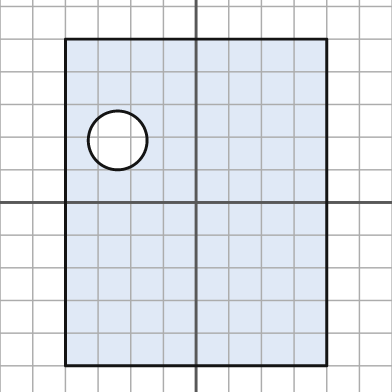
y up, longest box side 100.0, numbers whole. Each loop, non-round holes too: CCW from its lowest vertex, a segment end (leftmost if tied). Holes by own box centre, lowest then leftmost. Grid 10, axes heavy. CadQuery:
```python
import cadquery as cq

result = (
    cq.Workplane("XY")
    .moveTo(-40.0, -50.0)
    .lineTo(40.0, -50.0)
    .lineTo(40.0, 50.0)
    .lineTo(-40.0, 50.0)
    .close()
    .moveTo(-24.0, 19.0)
    .circle(9.0)
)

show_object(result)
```